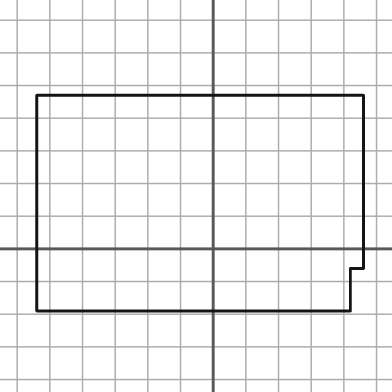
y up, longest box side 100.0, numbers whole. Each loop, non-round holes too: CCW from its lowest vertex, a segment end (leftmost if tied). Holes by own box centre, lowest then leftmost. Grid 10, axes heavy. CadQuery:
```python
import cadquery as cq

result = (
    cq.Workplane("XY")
    .moveTo(-54.0, -19.0)
    .lineTo(42.0, -19.0)
    .lineTo(42.0, -6.0)
    .lineTo(46.0, -6.0)
    .lineTo(46.0, 47.0)
    .lineTo(-54.0, 47.0)
    .close()
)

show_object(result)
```